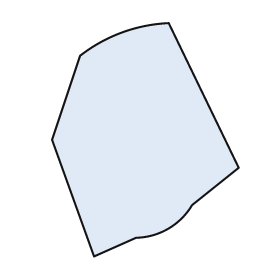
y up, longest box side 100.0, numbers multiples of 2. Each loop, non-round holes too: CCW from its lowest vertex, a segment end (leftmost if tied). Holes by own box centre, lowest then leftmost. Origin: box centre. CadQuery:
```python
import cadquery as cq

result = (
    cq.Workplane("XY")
    .moveTo(-22.0, -50.0)
    .lineTo(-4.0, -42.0)
    .threePointArc((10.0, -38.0), (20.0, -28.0))
    .lineTo(40.0, -12.0)
    .lineTo(10.0, 50.0)
    .threePointArc((-10.0, 46.0), (-28.0, 36.0))
    .lineTo(-40.0, 0.0)
    .close()
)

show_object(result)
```